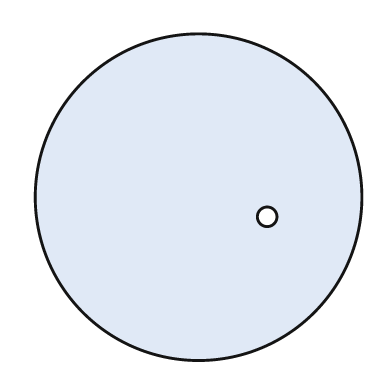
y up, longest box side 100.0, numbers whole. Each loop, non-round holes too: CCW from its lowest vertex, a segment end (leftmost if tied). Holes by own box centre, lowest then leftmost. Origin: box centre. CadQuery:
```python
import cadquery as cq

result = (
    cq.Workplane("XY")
    .moveTo(0.0, 0.0)
    .circle(50.0)
    .moveTo(21.0, -6.0)
    .circle(3.0)
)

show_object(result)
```